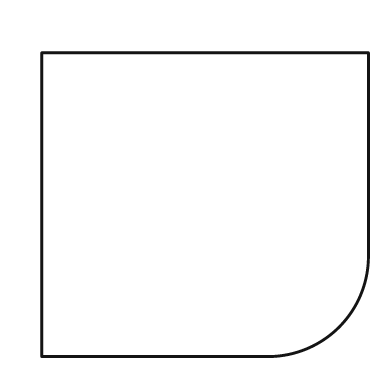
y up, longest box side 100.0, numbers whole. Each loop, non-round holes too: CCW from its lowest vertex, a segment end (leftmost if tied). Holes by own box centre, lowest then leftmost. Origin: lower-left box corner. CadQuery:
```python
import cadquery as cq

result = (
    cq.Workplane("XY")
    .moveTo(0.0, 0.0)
    .lineTo(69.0, 0.0)
    .threePointArc((91.0, 9.0), (100.0, 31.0))
    .lineTo(100.0, 93.0)
    .lineTo(0.0, 93.0)
    .close()
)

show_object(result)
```